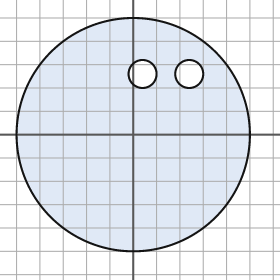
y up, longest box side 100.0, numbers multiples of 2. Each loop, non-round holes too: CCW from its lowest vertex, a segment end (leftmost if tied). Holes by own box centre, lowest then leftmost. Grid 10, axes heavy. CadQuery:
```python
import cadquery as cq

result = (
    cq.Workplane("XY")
    .moveTo(0.0, 0.0)
    .circle(50.0)
    .moveTo(4.0, 26.0)
    .circle(6.0)
    .moveTo(24.0, 26.0)
    .circle(6.0)
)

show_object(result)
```